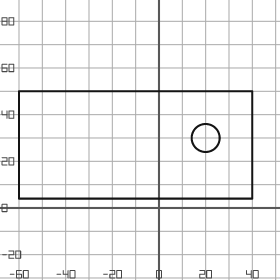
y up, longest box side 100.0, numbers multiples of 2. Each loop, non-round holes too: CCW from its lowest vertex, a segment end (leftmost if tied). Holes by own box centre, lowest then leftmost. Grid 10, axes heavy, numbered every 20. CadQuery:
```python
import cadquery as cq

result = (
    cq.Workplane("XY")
    .moveTo(-60.0, 4.0)
    .lineTo(40.0, 4.0)
    .lineTo(40.0, 50.0)
    .lineTo(-60.0, 50.0)
    .close()
    .moveTo(20.0, 30.0)
    .circle(6.0)
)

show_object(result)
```